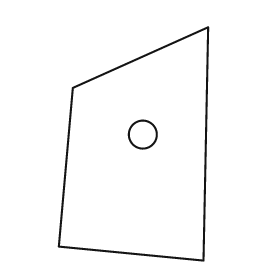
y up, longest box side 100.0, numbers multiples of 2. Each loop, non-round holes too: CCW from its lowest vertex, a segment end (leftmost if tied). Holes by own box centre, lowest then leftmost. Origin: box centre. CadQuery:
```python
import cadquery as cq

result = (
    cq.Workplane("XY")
    .moveTo(30.0, -50.0)
    .lineTo(32.0, 50.0)
    .lineTo(-26.0, 24.0)
    .lineTo(-32.0, -44.0)
    .close()
    .moveTo(4.0, 4.0)
    .circle(6.0)
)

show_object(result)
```